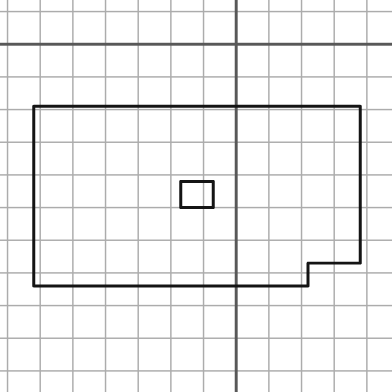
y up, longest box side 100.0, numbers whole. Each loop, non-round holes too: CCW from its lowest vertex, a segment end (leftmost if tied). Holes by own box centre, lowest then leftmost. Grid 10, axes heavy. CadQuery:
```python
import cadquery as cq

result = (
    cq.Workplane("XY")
    .moveTo(-62.0, -74.0)
    .lineTo(22.0, -74.0)
    .lineTo(22.0, -67.0)
    .lineTo(38.0, -67.0)
    .lineTo(38.0, -19.0)
    .lineTo(-62.0, -19.0)
    .close()
    .moveTo(-17.0, -50.0)
    .lineTo(-7.0, -50.0)
    .lineTo(-7.0, -42.0)
    .lineTo(-17.0, -42.0)
    .close()
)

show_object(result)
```